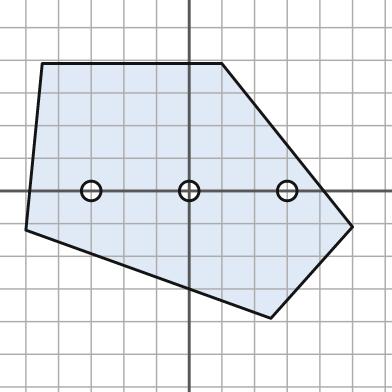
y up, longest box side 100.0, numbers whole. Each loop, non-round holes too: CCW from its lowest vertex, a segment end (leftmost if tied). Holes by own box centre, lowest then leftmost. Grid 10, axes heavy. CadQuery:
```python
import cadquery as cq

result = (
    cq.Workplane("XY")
    .moveTo(25.0, -39.0)
    .lineTo(50.0, -11.0)
    .lineTo(10.0, 39.0)
    .lineTo(-45.0, 39.0)
    .lineTo(-50.0, -12.0)
    .close()
    .moveTo(-30.0, 0.0)
    .circle(3.0)
    .moveTo(0.0, 0.0)
    .circle(3.0)
    .moveTo(30.0, 0.0)
    .circle(3.0)
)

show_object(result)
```